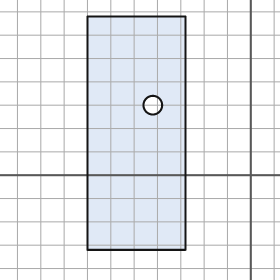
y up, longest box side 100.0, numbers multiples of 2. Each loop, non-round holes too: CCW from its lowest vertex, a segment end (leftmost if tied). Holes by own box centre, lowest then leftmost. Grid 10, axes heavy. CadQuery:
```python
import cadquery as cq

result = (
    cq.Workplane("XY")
    .moveTo(-70.0, -32.0)
    .lineTo(-28.0, -32.0)
    .lineTo(-28.0, 68.0)
    .lineTo(-70.0, 68.0)
    .close()
    .moveTo(-42.0, 30.0)
    .circle(4.0)
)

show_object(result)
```